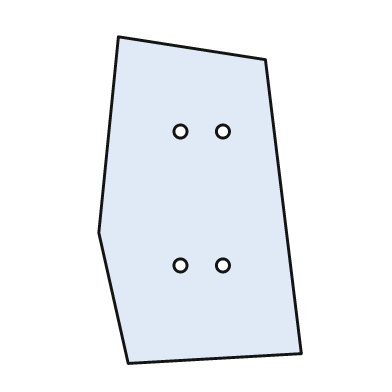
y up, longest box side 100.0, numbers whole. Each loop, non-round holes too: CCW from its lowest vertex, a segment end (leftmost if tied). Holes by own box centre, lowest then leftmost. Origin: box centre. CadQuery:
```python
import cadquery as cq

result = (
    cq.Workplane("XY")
    .moveTo(-22.0, -50.0)
    .lineTo(31.0, -47.0)
    .lineTo(20.0, 43.0)
    .lineTo(-25.0, 50.0)
    .lineTo(-31.0, -10.0)
    .close()
    .moveTo(-6.0, -20.0)
    .circle(2.0)
    .moveTo(7.0, -20.0)
    .circle(2.0)
    .moveTo(-6.0, 21.0)
    .circle(2.0)
    .moveTo(7.0, 21.0)
    .circle(2.0)
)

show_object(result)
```